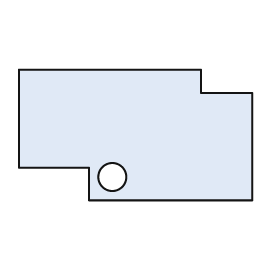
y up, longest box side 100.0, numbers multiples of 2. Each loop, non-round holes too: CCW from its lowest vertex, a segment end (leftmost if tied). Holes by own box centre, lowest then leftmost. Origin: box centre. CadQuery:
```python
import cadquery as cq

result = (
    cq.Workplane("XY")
    .moveTo(-20.0, -28.0)
    .lineTo(50.0, -28.0)
    .lineTo(50.0, 18.0)
    .lineTo(28.0, 18.0)
    .lineTo(28.0, 28.0)
    .lineTo(-50.0, 28.0)
    .lineTo(-50.0, -14.0)
    .lineTo(-20.0, -14.0)
    .close()
    .moveTo(-10.0, -18.0)
    .circle(6.0)
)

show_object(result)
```